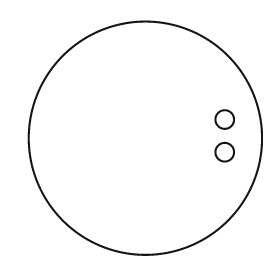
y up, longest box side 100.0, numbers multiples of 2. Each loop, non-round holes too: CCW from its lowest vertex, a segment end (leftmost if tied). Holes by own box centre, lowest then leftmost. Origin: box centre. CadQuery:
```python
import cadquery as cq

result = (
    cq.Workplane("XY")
    .moveTo(0.0, 0.0)
    .circle(50.0)
    .moveTo(34.0, -6.0)
    .circle(4.0)
    .moveTo(34.0, 8.0)
    .circle(4.0)
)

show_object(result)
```